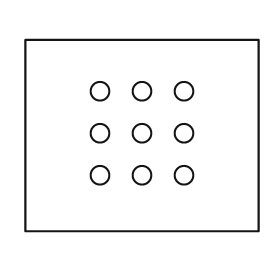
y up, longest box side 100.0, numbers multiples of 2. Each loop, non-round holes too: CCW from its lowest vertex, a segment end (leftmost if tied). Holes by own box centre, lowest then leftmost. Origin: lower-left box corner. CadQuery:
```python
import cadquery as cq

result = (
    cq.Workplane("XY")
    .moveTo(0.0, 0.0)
    .lineTo(100.0, 0.0)
    .lineTo(100.0, 82.0)
    .lineTo(0.0, 82.0)
    .close()
    .moveTo(32.0, 24.0)
    .circle(4.0)
    .moveTo(50.0, 24.0)
    .circle(4.0)
    .moveTo(68.0, 24.0)
    .circle(4.0)
    .moveTo(32.0, 42.0)
    .circle(4.0)
    .moveTo(50.0, 42.0)
    .circle(4.0)
    .moveTo(68.0, 42.0)
    .circle(4.0)
    .moveTo(32.0, 60.0)
    .circle(4.0)
    .moveTo(50.0, 60.0)
    .circle(4.0)
    .moveTo(68.0, 60.0)
    .circle(4.0)
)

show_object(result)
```